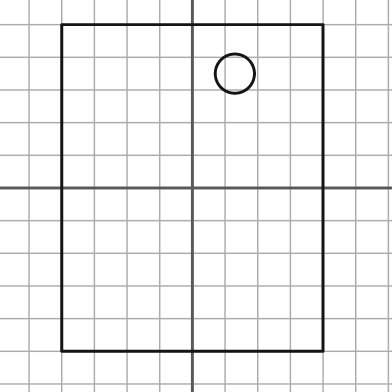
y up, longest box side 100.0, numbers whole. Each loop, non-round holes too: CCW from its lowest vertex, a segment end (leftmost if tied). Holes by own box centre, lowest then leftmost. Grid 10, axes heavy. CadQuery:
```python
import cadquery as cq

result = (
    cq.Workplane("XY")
    .moveTo(-40.0, -50.0)
    .lineTo(40.0, -50.0)
    .lineTo(40.0, 50.0)
    .lineTo(-40.0, 50.0)
    .close()
    .moveTo(13.0, 35.0)
    .circle(6.0)
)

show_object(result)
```